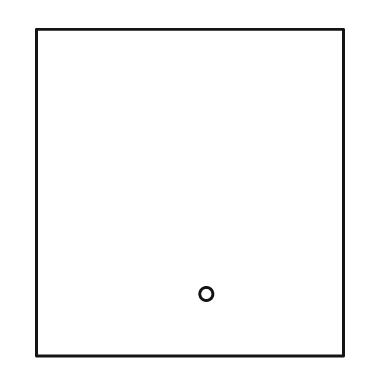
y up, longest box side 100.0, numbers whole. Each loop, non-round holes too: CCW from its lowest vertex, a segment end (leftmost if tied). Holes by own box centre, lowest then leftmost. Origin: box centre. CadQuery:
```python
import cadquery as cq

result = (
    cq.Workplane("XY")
    .moveTo(-47.0, -50.0)
    .lineTo(47.0, -50.0)
    .lineTo(47.0, 50.0)
    .lineTo(-47.0, 50.0)
    .close()
    .moveTo(5.0, -31.0)
    .circle(2.0)
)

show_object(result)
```